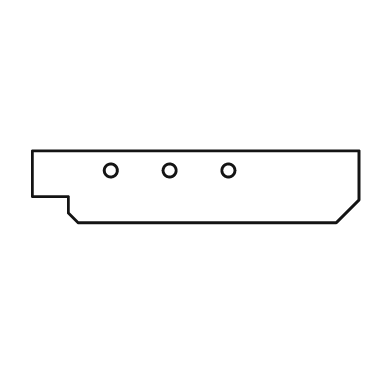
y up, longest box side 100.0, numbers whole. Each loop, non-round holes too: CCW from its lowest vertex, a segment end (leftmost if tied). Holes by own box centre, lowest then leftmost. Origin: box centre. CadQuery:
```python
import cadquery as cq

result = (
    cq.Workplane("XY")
    .moveTo(-36.0, -11.0)
    .lineTo(43.0, -11.0)
    .lineTo(50.0, -4.0)
    .lineTo(50.0, 11.0)
    .lineTo(-50.0, 11.0)
    .lineTo(-50.0, -3.0)
    .lineTo(-39.0, -3.0)
    .lineTo(-39.0, -8.0)
    .close()
    .moveTo(-26.0, 5.0)
    .circle(2.0)
    .moveTo(-8.0, 5.0)
    .circle(2.0)
    .moveTo(10.0, 5.0)
    .circle(2.0)
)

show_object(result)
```